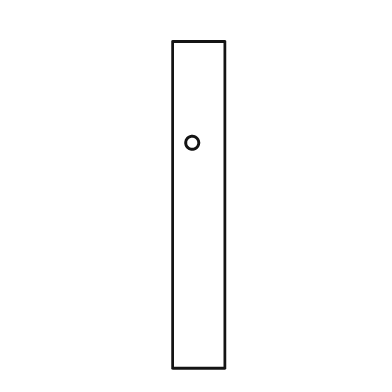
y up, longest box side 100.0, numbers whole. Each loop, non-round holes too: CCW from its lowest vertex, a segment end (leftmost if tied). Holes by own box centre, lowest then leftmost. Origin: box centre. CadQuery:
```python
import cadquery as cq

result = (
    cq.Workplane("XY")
    .moveTo(-8.0, -50.0)
    .lineTo(8.0, -50.0)
    .lineTo(8.0, 50.0)
    .lineTo(-8.0, 50.0)
    .close()
    .moveTo(-2.0, 19.0)
    .circle(2.0)
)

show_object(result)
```